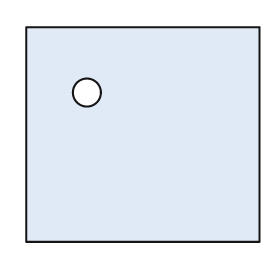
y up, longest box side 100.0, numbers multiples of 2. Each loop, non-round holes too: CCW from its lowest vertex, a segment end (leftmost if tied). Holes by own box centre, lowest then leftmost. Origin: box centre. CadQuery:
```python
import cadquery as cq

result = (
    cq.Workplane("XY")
    .moveTo(-50.0, -46.0)
    .lineTo(50.0, -46.0)
    .lineTo(50.0, 46.0)
    .lineTo(-50.0, 46.0)
    .close()
    .moveTo(-24.0, 18.0)
    .circle(6.0)
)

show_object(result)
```